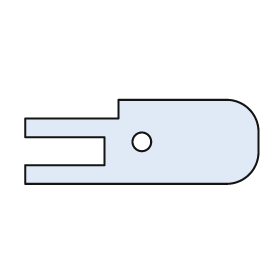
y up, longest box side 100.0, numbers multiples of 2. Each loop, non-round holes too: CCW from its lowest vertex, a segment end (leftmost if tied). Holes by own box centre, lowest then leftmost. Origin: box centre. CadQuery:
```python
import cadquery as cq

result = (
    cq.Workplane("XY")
    .moveTo(-50.0, -18.0)
    .lineTo(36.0, -18.0)
    .threePointArc((46.0, -14.0), (50.0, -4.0))
    .lineTo(50.0, 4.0)
    .threePointArc((46.0, 14.0), (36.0, 18.0))
    .lineTo(-10.0, 18.0)
    .lineTo(-10.0, 10.0)
    .lineTo(-50.0, 10.0)
    .lineTo(-50.0, 2.0)
    .lineTo(-16.0, 2.0)
    .lineTo(-16.0, -10.0)
    .lineTo(-50.0, -10.0)
    .close()
    .moveTo(0.0, 0.0)
    .circle(4.0)
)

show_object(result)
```